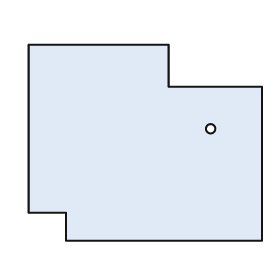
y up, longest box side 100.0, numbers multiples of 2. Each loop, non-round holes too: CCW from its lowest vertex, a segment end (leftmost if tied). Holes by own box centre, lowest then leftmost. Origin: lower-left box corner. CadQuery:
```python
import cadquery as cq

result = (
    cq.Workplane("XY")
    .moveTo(16.0, 0.0)
    .lineTo(100.0, 0.0)
    .lineTo(100.0, 66.0)
    .lineTo(60.0, 66.0)
    .lineTo(60.0, 84.0)
    .lineTo(0.0, 84.0)
    .lineTo(0.0, 12.0)
    .lineTo(16.0, 12.0)
    .close()
    .moveTo(78.0, 48.0)
    .circle(2.0)
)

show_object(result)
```